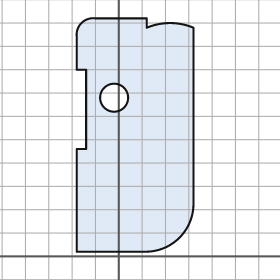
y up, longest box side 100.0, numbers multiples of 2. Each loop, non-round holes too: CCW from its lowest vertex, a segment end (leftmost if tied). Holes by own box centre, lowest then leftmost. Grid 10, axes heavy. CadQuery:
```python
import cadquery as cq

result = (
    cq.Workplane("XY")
    .moveTo(-18.0, 2.0)
    .lineTo(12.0, 2.0)
    .threePointArc((26.0, 8.0), (32.0, 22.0))
    .lineTo(32.0, 98.0)
    .threePointArc((22.0, 100.0), (12.0, 98.0))
    .lineTo(12.0, 102.0)
    .lineTo(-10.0, 102.0)
    .threePointArc((-16.0, 100.0), (-18.0, 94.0))
    .lineTo(-18.0, 80.0)
    .lineTo(-14.0, 80.0)
    .lineTo(-14.0, 46.0)
    .lineTo(-18.0, 46.0)
    .close()
    .moveTo(-2.0, 68.0)
    .circle(6.0)
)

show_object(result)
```